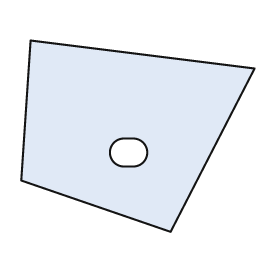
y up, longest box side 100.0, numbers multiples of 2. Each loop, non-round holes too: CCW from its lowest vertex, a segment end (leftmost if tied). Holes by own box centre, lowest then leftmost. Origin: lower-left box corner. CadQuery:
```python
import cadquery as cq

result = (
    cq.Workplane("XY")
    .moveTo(64.0, 0.0)
    .lineTo(100.0, 70.0)
    .lineTo(4.0, 82.0)
    .lineTo(0.0, 22.0)
    .close()
    .moveTo(44.0, 28.0)
    .lineTo(48.0, 28.0)
    .threePointArc((54.0, 34.0), (48.0, 40.0))
    .lineTo(44.0, 40.0)
    .threePointArc((38.0, 34.0), (44.0, 28.0))
    .close()
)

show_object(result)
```